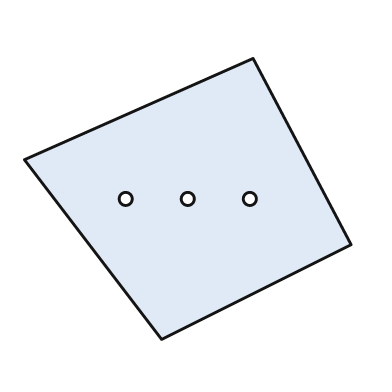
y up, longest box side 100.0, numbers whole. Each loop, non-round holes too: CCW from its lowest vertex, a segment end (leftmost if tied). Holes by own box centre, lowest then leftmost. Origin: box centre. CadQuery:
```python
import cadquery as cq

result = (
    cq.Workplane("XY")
    .moveTo(-8.0, -43.0)
    .lineTo(50.0, -14.0)
    .lineTo(20.0, 43.0)
    .lineTo(-50.0, 12.0)
    .close()
    .moveTo(-19.0, 0.0)
    .circle(2.0)
    .moveTo(0.0, 0.0)
    .circle(2.0)
    .moveTo(19.0, 0.0)
    .circle(2.0)
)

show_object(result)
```